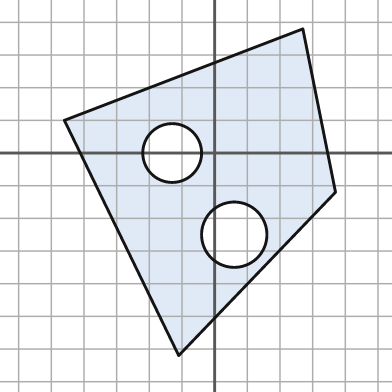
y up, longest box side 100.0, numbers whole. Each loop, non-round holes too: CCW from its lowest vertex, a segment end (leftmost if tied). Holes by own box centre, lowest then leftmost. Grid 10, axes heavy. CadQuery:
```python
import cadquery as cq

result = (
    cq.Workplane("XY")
    .moveTo(-11.0, -62.0)
    .lineTo(37.0, -12.0)
    .lineTo(27.0, 38.0)
    .lineTo(-46.0, 10.0)
    .close()
    .moveTo(6.0, -25.0)
    .circle(10.0)
    .moveTo(-13.0, 0.0)
    .circle(9.0)
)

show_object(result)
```